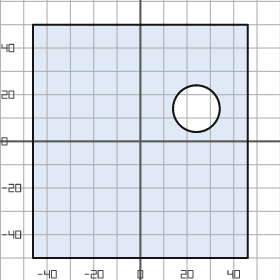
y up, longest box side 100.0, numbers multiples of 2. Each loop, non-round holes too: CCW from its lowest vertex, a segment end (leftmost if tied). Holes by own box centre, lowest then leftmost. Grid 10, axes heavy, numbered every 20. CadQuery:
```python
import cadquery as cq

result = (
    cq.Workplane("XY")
    .moveTo(-46.0, -50.0)
    .lineTo(46.0, -50.0)
    .lineTo(46.0, 50.0)
    .lineTo(-46.0, 50.0)
    .close()
    .moveTo(24.0, 14.0)
    .circle(10.0)
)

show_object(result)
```